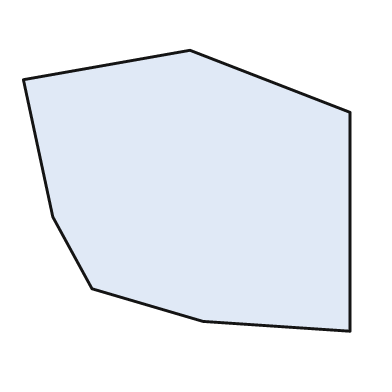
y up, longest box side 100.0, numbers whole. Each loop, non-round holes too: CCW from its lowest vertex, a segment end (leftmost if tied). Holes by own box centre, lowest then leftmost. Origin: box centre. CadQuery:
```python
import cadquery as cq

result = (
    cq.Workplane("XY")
    .moveTo(50.0, -43.0)
    .lineTo(50.0, 24.0)
    .lineTo(1.0, 43.0)
    .lineTo(-50.0, 34.0)
    .lineTo(-41.0, -8.0)
    .lineTo(-29.0, -30.0)
    .lineTo(5.0, -40.0)
    .close()
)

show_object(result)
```